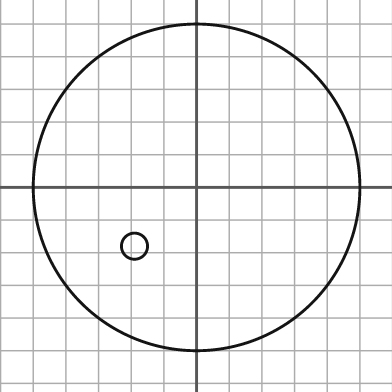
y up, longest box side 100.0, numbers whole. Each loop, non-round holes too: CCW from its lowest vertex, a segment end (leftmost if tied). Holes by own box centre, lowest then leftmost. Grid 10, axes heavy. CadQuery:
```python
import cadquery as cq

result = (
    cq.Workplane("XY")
    .moveTo(0.0, 0.0)
    .circle(50.0)
    .moveTo(-19.0, -18.0)
    .circle(4.0)
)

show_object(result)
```